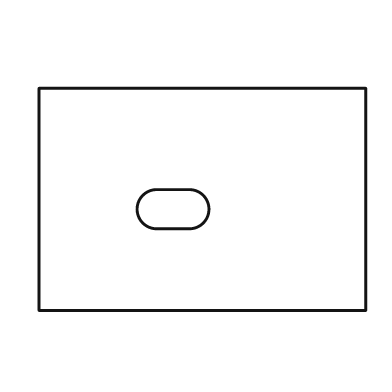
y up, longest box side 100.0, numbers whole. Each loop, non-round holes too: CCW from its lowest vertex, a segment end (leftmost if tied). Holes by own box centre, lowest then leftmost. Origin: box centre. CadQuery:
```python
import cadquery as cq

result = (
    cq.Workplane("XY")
    .moveTo(-50.0, -34.0)
    .lineTo(50.0, -34.0)
    .lineTo(50.0, 34.0)
    .lineTo(-50.0, 34.0)
    .close()
    .moveTo(-14.0, -9.0)
    .lineTo(-4.0, -9.0)
    .threePointArc((2.0, -3.0), (-4.0, 3.0))
    .lineTo(-14.0, 3.0)
    .threePointArc((-20.0, -3.0), (-14.0, -9.0))
    .close()
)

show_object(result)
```